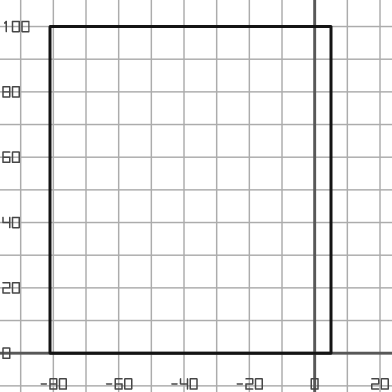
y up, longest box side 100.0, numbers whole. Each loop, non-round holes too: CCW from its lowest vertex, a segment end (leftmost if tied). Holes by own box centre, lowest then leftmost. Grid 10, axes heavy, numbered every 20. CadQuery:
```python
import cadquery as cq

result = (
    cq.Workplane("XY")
    .moveTo(-81.0, 0.0)
    .lineTo(5.0, 0.0)
    .lineTo(5.0, 100.0)
    .lineTo(-81.0, 100.0)
    .close()
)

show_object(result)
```